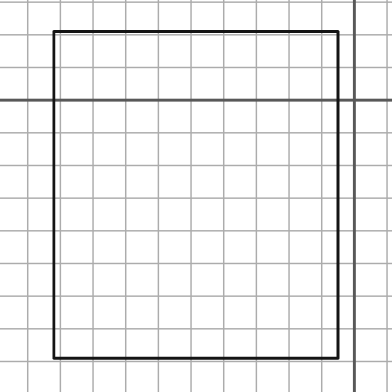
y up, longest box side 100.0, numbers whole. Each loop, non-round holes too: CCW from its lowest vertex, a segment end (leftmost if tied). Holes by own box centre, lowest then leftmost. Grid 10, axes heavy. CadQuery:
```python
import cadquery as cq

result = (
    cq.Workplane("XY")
    .moveTo(-92.0, -79.0)
    .lineTo(-5.0, -79.0)
    .lineTo(-5.0, 21.0)
    .lineTo(-92.0, 21.0)
    .close()
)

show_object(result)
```